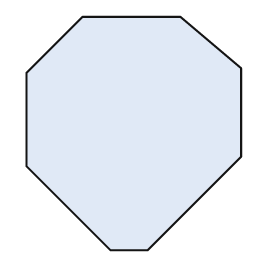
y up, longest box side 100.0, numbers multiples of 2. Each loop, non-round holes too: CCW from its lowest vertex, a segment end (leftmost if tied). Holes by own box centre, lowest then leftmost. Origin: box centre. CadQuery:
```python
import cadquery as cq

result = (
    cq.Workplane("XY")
    .moveTo(-10.0, -50.0)
    .lineTo(6.0, -50.0)
    .lineTo(46.0, -10.0)
    .lineTo(46.0, 28.0)
    .lineTo(20.0, 50.0)
    .lineTo(-22.0, 50.0)
    .lineTo(-46.0, 26.0)
    .lineTo(-46.0, -14.0)
    .close()
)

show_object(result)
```